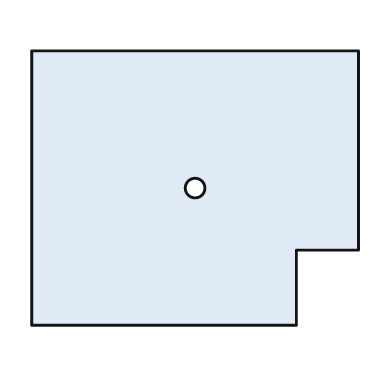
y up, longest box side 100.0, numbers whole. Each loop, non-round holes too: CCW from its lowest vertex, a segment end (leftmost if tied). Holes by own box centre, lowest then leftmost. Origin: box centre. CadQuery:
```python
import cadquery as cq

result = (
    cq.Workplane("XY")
    .moveTo(-50.0, -42.0)
    .lineTo(31.0, -42.0)
    .lineTo(31.0, -19.0)
    .lineTo(50.0, -19.0)
    .lineTo(50.0, 42.0)
    .lineTo(-50.0, 42.0)
    .close()
    .moveTo(0.0, 0.0)
    .circle(3.0)
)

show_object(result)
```